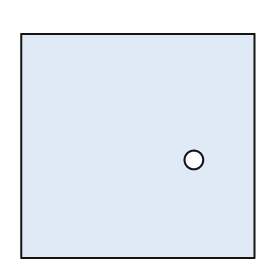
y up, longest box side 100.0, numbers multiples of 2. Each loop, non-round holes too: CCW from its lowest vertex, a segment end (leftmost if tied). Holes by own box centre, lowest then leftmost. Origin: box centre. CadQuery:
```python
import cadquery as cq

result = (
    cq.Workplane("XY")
    .moveTo(-50.0, -48.0)
    .lineTo(50.0, -48.0)
    .lineTo(50.0, 48.0)
    .lineTo(-50.0, 48.0)
    .close()
    .moveTo(24.0, -6.0)
    .circle(4.0)
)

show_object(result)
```